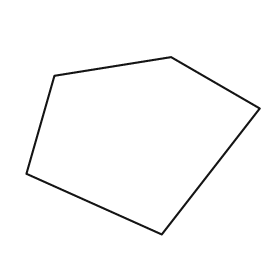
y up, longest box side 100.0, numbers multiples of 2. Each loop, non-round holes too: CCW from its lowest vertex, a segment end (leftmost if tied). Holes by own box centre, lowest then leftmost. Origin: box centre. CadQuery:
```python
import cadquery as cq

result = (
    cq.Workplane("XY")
    .moveTo(8.0, -38.0)
    .lineTo(50.0, 16.0)
    .lineTo(12.0, 38.0)
    .lineTo(-38.0, 30.0)
    .lineTo(-50.0, -12.0)
    .close()
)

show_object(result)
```